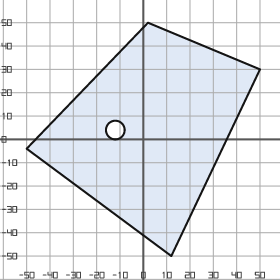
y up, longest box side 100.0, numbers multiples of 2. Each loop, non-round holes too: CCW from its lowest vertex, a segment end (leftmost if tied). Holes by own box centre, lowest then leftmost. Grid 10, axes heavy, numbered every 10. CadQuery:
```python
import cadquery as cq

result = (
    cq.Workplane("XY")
    .moveTo(12.0, -50.0)
    .lineTo(50.0, 30.0)
    .lineTo(2.0, 50.0)
    .lineTo(-50.0, -4.0)
    .close()
    .moveTo(-12.0, 4.0)
    .circle(4.0)
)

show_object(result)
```